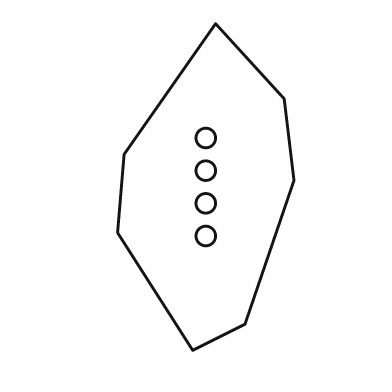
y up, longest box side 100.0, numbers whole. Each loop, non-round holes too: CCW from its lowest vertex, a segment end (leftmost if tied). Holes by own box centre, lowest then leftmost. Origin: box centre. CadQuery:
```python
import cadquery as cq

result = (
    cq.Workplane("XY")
    .moveTo(-4.0, -50.0)
    .lineTo(12.0, -42.0)
    .lineTo(27.0, 2.0)
    .lineTo(24.0, 27.0)
    .lineTo(3.0, 50.0)
    .lineTo(-25.0, 10.0)
    .lineTo(-27.0, -14.0)
    .close()
    .moveTo(0.0, -15.0)
    .circle(3.0)
    .moveTo(0.0, -5.0)
    .circle(3.0)
    .moveTo(0.0, 5.0)
    .circle(3.0)
    .moveTo(0.0, 15.0)
    .circle(3.0)
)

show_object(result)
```